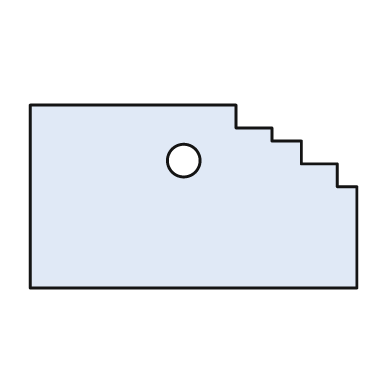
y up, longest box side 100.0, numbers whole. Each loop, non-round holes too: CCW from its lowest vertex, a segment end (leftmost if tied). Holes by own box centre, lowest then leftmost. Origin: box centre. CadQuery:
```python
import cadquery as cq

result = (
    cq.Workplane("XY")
    .moveTo(-50.0, -28.0)
    .lineTo(50.0, -28.0)
    .lineTo(50.0, 3.0)
    .lineTo(44.0, 3.0)
    .lineTo(44.0, 10.0)
    .lineTo(33.0, 10.0)
    .lineTo(33.0, 17.0)
    .lineTo(24.0, 17.0)
    .lineTo(24.0, 21.0)
    .lineTo(13.0, 21.0)
    .lineTo(13.0, 28.0)
    .lineTo(-50.0, 28.0)
    .close()
    .moveTo(-3.0, 11.0)
    .circle(5.0)
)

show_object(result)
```